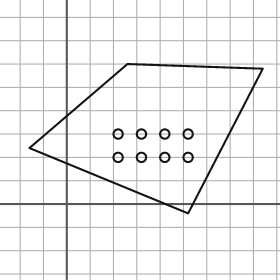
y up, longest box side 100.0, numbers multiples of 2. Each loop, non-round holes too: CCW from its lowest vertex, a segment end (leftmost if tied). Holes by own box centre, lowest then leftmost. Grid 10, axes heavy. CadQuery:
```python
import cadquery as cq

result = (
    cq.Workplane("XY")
    .moveTo(52.0, -4.0)
    .lineTo(84.0, 58.0)
    .lineTo(26.0, 60.0)
    .lineTo(-16.0, 24.0)
    .close()
    .moveTo(22.0, 20.0)
    .circle(2.0)
    .moveTo(32.0, 20.0)
    .circle(2.0)
    .moveTo(42.0, 20.0)
    .circle(2.0)
    .moveTo(52.0, 20.0)
    .circle(2.0)
    .moveTo(22.0, 30.0)
    .circle(2.0)
    .moveTo(32.0, 30.0)
    .circle(2.0)
    .moveTo(42.0, 30.0)
    .circle(2.0)
    .moveTo(52.0, 30.0)
    .circle(2.0)
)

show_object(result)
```